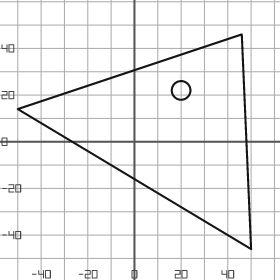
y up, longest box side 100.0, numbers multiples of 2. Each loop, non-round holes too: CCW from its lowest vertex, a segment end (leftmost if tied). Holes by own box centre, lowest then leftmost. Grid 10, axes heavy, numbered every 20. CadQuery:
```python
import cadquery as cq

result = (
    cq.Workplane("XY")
    .moveTo(50.0, -46.0)
    .lineTo(46.0, 46.0)
    .lineTo(-50.0, 14.0)
    .close()
    .moveTo(20.0, 22.0)
    .circle(4.0)
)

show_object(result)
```